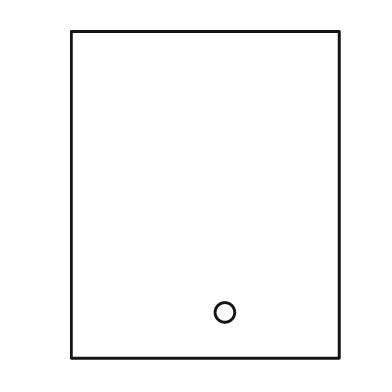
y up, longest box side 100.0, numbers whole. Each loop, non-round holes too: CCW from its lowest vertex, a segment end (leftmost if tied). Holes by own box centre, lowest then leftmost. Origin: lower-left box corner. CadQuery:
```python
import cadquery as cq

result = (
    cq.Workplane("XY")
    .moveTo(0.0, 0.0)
    .lineTo(82.0, 0.0)
    .lineTo(82.0, 100.0)
    .lineTo(0.0, 100.0)
    .close()
    .moveTo(47.0, 14.0)
    .circle(3.0)
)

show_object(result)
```